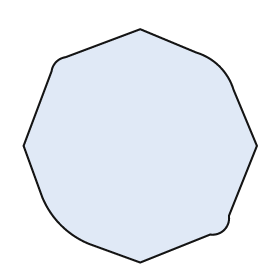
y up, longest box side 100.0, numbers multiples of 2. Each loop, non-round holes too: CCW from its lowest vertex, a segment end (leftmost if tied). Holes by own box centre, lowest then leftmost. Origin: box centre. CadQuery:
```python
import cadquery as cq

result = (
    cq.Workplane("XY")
    .moveTo(0.0, -50.0)
    .lineTo(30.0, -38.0)
    .threePointArc((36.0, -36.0), (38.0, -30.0))
    .lineTo(50.0, 0.0)
    .lineTo(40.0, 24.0)
    .threePointArc((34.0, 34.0), (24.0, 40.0))
    .lineTo(0.0, 50.0)
    .lineTo(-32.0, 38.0)
    .threePointArc((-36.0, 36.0), (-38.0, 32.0))
    .lineTo(-50.0, 0.0)
    .lineTo(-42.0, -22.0)
    .threePointArc((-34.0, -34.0), (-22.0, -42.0))
    .close()
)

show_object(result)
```